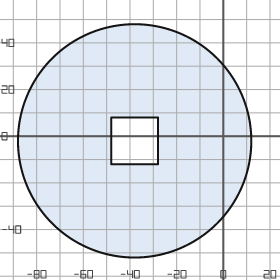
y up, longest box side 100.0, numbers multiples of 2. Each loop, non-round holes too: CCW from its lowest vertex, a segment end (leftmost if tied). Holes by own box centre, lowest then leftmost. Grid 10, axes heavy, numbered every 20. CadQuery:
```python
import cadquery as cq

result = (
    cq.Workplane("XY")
    .moveTo(-38.0, -2.0)
    .circle(50.0)
    .moveTo(-48.0, -12.0)
    .lineTo(-28.0, -12.0)
    .lineTo(-28.0, 8.0)
    .lineTo(-48.0, 8.0)
    .close()
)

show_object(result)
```